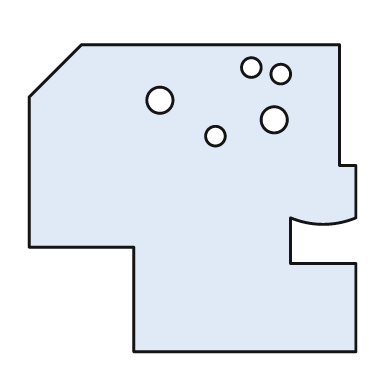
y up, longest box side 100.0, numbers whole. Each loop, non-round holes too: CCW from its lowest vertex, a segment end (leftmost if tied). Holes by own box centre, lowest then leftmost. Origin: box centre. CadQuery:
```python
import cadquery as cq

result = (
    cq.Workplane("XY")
    .moveTo(-18.0, -47.0)
    .lineTo(50.0, -47.0)
    .lineTo(50.0, -20.0)
    .lineTo(30.0, -20.0)
    .lineTo(30.0, -6.0)
    .threePointArc((40.0, -8.0), (50.0, -6.0))
    .lineTo(50.0, 10.0)
    .lineTo(45.0, 10.0)
    .lineTo(45.0, 47.0)
    .lineTo(-34.0, 47.0)
    .lineTo(-50.0, 31.0)
    .lineTo(-50.0, -15.0)
    .lineTo(-18.0, -15.0)
    .close()
    .moveTo(7.0, 19.0)
    .circle(3.0)
    .moveTo(25.0, 24.0)
    .circle(4.0)
    .moveTo(-10.0, 30.0)
    .circle(4.0)
    .moveTo(27.0, 38.0)
    .circle(3.0)
    .moveTo(18.0, 40.0)
    .circle(3.0)
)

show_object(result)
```